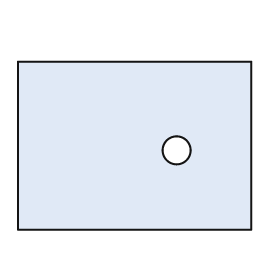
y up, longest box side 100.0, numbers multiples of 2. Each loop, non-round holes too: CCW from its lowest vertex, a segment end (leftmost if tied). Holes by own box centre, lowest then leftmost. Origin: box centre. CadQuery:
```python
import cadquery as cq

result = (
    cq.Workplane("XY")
    .moveTo(-50.0, -36.0)
    .lineTo(50.0, -36.0)
    .lineTo(50.0, 36.0)
    .lineTo(-50.0, 36.0)
    .close()
    .moveTo(18.0, -2.0)
    .circle(6.0)
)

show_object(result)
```